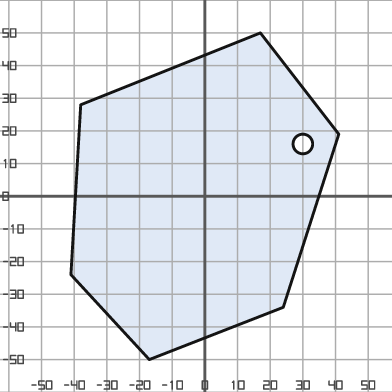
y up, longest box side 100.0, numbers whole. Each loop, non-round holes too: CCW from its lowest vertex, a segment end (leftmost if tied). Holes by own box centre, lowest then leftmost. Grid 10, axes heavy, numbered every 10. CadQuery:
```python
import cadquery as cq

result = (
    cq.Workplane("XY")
    .moveTo(-17.0, -50.0)
    .lineTo(24.0, -34.0)
    .lineTo(41.0, 19.0)
    .lineTo(17.0, 50.0)
    .lineTo(-38.0, 28.0)
    .lineTo(-41.0, -24.0)
    .close()
    .moveTo(30.0, 16.0)
    .circle(3.0)
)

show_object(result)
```